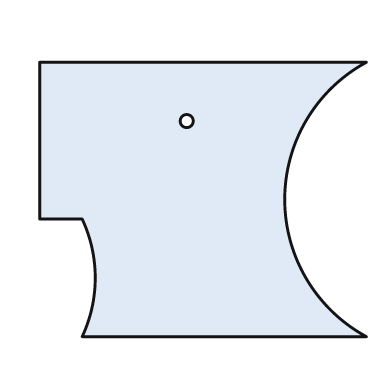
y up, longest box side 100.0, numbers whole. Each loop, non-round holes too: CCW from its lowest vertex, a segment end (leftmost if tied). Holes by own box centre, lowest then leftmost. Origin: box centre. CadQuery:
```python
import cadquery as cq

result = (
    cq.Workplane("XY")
    .moveTo(-37.0, -42.0)
    .lineTo(50.0, -42.0)
    .threePointArc((25.0, 0.0), (50.0, 42.0))
    .lineTo(-50.0, 42.0)
    .lineTo(-50.0, -6.0)
    .lineTo(-37.0, -6.0)
    .threePointArc((-33.0, -24.0), (-37.0, -42.0))
    .close()
    .moveTo(-5.0, 24.0)
    .circle(2.0)
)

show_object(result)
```